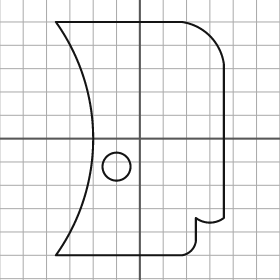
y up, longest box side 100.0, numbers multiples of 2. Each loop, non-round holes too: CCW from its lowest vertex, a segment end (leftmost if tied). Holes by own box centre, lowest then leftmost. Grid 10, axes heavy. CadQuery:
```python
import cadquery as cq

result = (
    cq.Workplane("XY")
    .moveTo(-36.0, -50.0)
    .lineTo(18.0, -50.0)
    .threePointArc((22.0, -48.0), (24.0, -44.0))
    .lineTo(24.0, -34.0)
    .threePointArc((30.0, -36.0), (36.0, -34.0))
    .lineTo(36.0, 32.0)
    .threePointArc((30.0, 44.0), (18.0, 50.0))
    .lineTo(-36.0, 50.0)
    .threePointArc((-20.0, 0.0), (-36.0, -50.0))
    .close()
    .moveTo(-10.0, -12.0)
    .circle(6.0)
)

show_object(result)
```